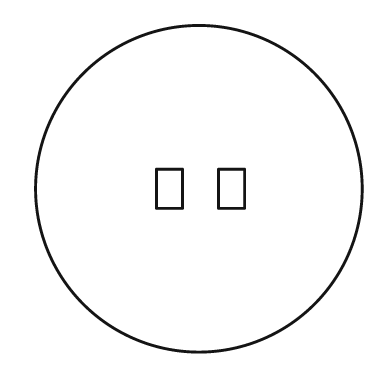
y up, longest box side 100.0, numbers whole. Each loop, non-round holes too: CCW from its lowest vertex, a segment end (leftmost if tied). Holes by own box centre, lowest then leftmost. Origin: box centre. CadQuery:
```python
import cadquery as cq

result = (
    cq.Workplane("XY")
    .moveTo(0.0, 0.0)
    .circle(50.0)
    .moveTo(-13.0, -6.0)
    .lineTo(-5.0, -6.0)
    .lineTo(-5.0, 6.0)
    .lineTo(-13.0, 6.0)
    .close()
    .moveTo(6.0, -6.0)
    .lineTo(14.0, -6.0)
    .lineTo(14.0, 6.0)
    .lineTo(6.0, 6.0)
    .close()
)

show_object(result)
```